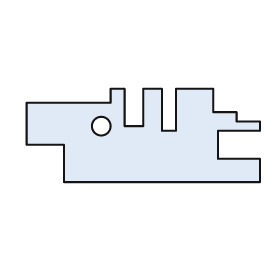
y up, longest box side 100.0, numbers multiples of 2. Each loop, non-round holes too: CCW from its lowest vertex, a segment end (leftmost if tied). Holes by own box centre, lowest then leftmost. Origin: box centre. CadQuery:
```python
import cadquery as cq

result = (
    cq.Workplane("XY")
    .moveTo(-34.0, -20.0)
    .lineTo(50.0, -20.0)
    .lineTo(50.0, -10.0)
    .lineTo(32.0, -10.0)
    .lineTo(32.0, 2.0)
    .lineTo(50.0, 2.0)
    .lineTo(50.0, 6.0)
    .lineTo(40.0, 6.0)
    .lineTo(40.0, 10.0)
    .lineTo(30.0, 10.0)
    .lineTo(30.0, 20.0)
    .lineTo(14.0, 20.0)
    .lineTo(14.0, 2.0)
    .lineTo(8.0, 2.0)
    .lineTo(8.0, 20.0)
    .lineTo(0.0, 20.0)
    .lineTo(0.0, 4.0)
    .lineTo(-8.0, 4.0)
    .lineTo(-8.0, 20.0)
    .lineTo(-14.0, 20.0)
    .lineTo(-14.0, 14.0)
    .lineTo(-50.0, 14.0)
    .lineTo(-50.0, -4.0)
    .lineTo(-34.0, -4.0)
    .close()
    .moveTo(-18.0, 4.0)
    .circle(4.0)
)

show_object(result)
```